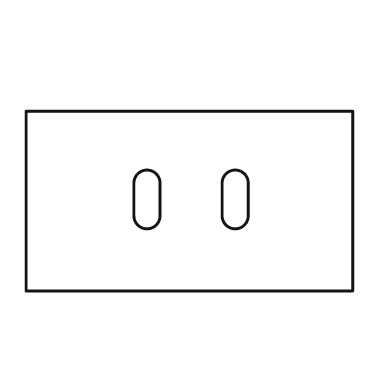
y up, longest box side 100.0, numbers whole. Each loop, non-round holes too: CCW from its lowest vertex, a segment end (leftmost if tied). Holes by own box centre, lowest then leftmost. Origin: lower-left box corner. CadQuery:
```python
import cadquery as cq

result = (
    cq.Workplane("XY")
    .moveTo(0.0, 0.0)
    .lineTo(100.0, 0.0)
    .lineTo(100.0, 55.0)
    .lineTo(0.0, 55.0)
    .close()
    .moveTo(33.0, 23.0)
    .threePointArc((37.0, 19.0), (41.0, 23.0))
    .lineTo(41.0, 33.0)
    .threePointArc((37.0, 37.0), (33.0, 33.0))
    .close()
    .moveTo(60.0, 23.0)
    .threePointArc((64.0, 19.0), (68.0, 23.0))
    .lineTo(68.0, 33.0)
    .threePointArc((64.0, 37.0), (60.0, 33.0))
    .close()
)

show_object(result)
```